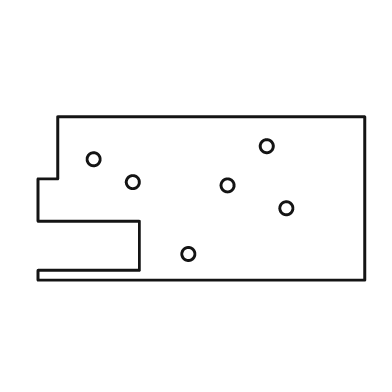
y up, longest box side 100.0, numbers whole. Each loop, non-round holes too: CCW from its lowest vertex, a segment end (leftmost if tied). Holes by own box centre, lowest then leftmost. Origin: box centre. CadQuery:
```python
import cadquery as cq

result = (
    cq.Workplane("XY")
    .moveTo(-50.0, -25.0)
    .lineTo(50.0, -25.0)
    .lineTo(50.0, 25.0)
    .lineTo(-44.0, 25.0)
    .lineTo(-44.0, 6.0)
    .lineTo(-50.0, 6.0)
    .lineTo(-50.0, -7.0)
    .lineTo(-19.0, -7.0)
    .lineTo(-19.0, -22.0)
    .lineTo(-50.0, -22.0)
    .close()
    .moveTo(-4.0, -17.0)
    .circle(2.0)
    .moveTo(26.0, -3.0)
    .circle(2.0)
    .moveTo(8.0, 4.0)
    .circle(2.0)
    .moveTo(-21.0, 5.0)
    .circle(2.0)
    .moveTo(-33.0, 12.0)
    .circle(2.0)
    .moveTo(20.0, 16.0)
    .circle(2.0)
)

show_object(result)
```